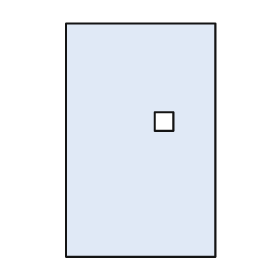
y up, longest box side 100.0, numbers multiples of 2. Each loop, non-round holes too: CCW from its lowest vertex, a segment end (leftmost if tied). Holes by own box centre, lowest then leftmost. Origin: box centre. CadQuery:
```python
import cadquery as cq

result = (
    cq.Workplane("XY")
    .moveTo(-32.0, -50.0)
    .lineTo(32.0, -50.0)
    .lineTo(32.0, 50.0)
    .lineTo(-32.0, 50.0)
    .close()
    .moveTo(6.0, 4.0)
    .lineTo(14.0, 4.0)
    .lineTo(14.0, 12.0)
    .lineTo(6.0, 12.0)
    .close()
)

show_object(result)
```